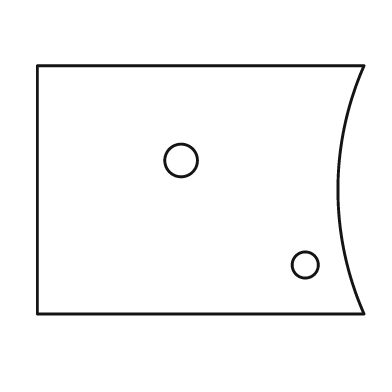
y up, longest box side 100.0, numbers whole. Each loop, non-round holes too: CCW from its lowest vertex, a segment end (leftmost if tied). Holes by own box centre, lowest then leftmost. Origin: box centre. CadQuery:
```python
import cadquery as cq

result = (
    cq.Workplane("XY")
    .moveTo(-50.0, -38.0)
    .lineTo(50.0, -38.0)
    .threePointArc((42.0, 0.0), (50.0, 38.0))
    .lineTo(-50.0, 38.0)
    .close()
    .moveTo(32.0, -23.0)
    .circle(4.0)
    .moveTo(-6.0, 9.0)
    .circle(5.0)
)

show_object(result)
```